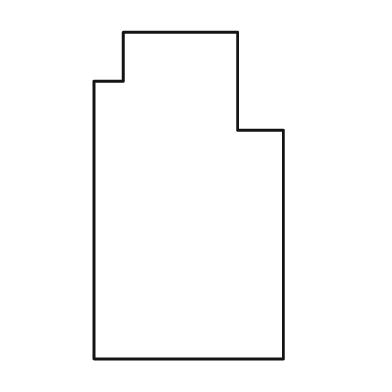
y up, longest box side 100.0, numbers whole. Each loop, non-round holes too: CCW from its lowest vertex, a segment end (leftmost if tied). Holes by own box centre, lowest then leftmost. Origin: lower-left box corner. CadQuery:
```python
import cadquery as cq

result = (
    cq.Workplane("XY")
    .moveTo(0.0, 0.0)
    .lineTo(58.0, 0.0)
    .lineTo(58.0, 70.0)
    .lineTo(44.0, 70.0)
    .lineTo(44.0, 100.0)
    .lineTo(9.0, 100.0)
    .lineTo(9.0, 85.0)
    .lineTo(0.0, 85.0)
    .close()
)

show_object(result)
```